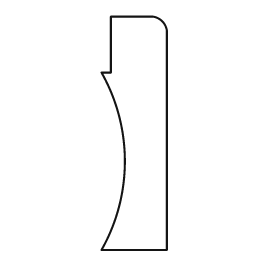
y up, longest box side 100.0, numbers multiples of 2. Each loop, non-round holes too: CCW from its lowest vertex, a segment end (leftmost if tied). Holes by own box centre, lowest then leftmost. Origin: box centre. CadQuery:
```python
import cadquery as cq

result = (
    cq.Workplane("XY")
    .moveTo(-14.0, -50.0)
    .lineTo(14.0, -50.0)
    .lineTo(14.0, 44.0)
    .threePointArc((12.0, 48.0), (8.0, 50.0))
    .lineTo(-10.0, 50.0)
    .lineTo(-10.0, 26.0)
    .lineTo(-14.0, 26.0)
    .threePointArc((-4.0, -12.0), (-14.0, -50.0))
    .close()
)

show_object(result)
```